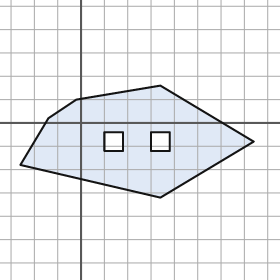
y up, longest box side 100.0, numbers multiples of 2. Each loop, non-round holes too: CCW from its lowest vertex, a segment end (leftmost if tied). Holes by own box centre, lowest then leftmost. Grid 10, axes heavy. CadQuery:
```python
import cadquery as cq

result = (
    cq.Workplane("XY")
    .moveTo(34.0, -32.0)
    .lineTo(74.0, -8.0)
    .lineTo(34.0, 16.0)
    .lineTo(-2.0, 10.0)
    .lineTo(-14.0, 2.0)
    .lineTo(-26.0, -18.0)
    .close()
    .moveTo(10.0, -12.0)
    .lineTo(18.0, -12.0)
    .lineTo(18.0, -4.0)
    .lineTo(10.0, -4.0)
    .close()
    .moveTo(30.0, -12.0)
    .lineTo(38.0, -12.0)
    .lineTo(38.0, -4.0)
    .lineTo(30.0, -4.0)
    .close()
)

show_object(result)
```